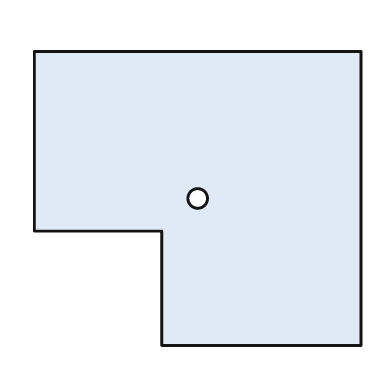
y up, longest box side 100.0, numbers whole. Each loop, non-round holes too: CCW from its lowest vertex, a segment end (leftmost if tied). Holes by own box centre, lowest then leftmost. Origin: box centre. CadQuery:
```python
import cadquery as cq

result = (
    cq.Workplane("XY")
    .moveTo(-11.0, -45.0)
    .lineTo(50.0, -45.0)
    .lineTo(50.0, 45.0)
    .lineTo(-50.0, 45.0)
    .lineTo(-50.0, -10.0)
    .lineTo(-11.0, -10.0)
    .close()
    .moveTo(0.0, 0.0)
    .circle(3.0)
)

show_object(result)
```